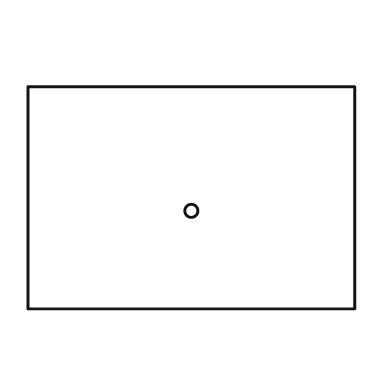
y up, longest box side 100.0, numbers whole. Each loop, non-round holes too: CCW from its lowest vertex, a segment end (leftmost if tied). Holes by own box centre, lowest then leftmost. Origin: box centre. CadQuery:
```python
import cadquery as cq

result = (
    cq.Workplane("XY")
    .moveTo(-50.0, -34.0)
    .lineTo(50.0, -34.0)
    .lineTo(50.0, 34.0)
    .lineTo(-50.0, 34.0)
    .close()
    .moveTo(0.0, -4.0)
    .circle(2.0)
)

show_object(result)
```